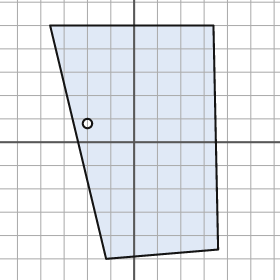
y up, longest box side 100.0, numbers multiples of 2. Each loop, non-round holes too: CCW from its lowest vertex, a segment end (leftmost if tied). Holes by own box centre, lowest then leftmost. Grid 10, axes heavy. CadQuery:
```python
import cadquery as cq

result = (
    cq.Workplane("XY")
    .moveTo(-12.0, -50.0)
    .lineTo(36.0, -46.0)
    .lineTo(34.0, 50.0)
    .lineTo(-36.0, 50.0)
    .close()
    .moveTo(-20.0, 8.0)
    .circle(2.0)
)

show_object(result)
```